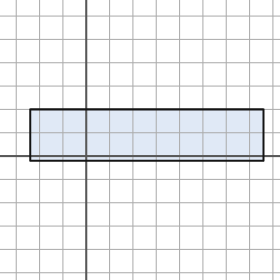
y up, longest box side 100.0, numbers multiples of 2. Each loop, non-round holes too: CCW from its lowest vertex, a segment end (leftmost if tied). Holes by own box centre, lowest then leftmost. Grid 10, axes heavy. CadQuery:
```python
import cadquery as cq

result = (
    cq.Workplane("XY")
    .moveTo(-24.0, -2.0)
    .lineTo(76.0, -2.0)
    .lineTo(76.0, 20.0)
    .lineTo(-24.0, 20.0)
    .close()
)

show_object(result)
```